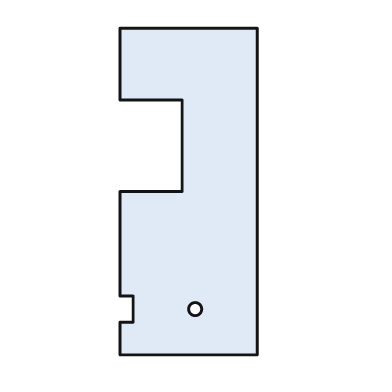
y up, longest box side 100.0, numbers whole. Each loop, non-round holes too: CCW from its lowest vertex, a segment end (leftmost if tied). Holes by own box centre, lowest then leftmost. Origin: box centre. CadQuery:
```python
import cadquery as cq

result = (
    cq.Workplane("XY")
    .moveTo(-21.0, -50.0)
    .lineTo(21.0, -50.0)
    .lineTo(21.0, 50.0)
    .lineTo(-21.0, 50.0)
    .lineTo(-21.0, 28.0)
    .lineTo(-2.0, 28.0)
    .lineTo(-2.0, 0.0)
    .lineTo(-21.0, 0.0)
    .lineTo(-21.0, -32.0)
    .lineTo(-17.0, -32.0)
    .lineTo(-17.0, -40.0)
    .lineTo(-21.0, -40.0)
    .close()
    .moveTo(2.0, -36.0)
    .circle(2.0)
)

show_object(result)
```